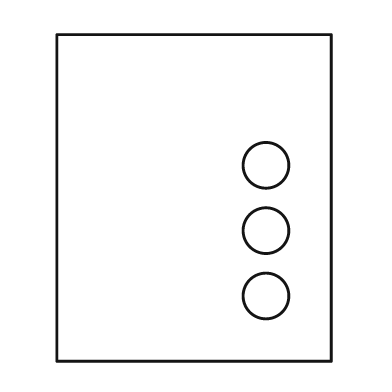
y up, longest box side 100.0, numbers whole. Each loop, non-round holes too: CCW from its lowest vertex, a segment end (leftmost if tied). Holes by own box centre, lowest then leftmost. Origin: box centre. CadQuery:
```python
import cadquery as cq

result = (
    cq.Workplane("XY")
    .moveTo(-42.0, -50.0)
    .lineTo(42.0, -50.0)
    .lineTo(42.0, 50.0)
    .lineTo(-42.0, 50.0)
    .close()
    .moveTo(22.0, -30.0)
    .circle(7.0)
    .moveTo(22.0, -10.0)
    .circle(7.0)
    .moveTo(22.0, 10.0)
    .circle(7.0)
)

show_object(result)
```